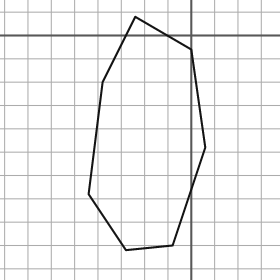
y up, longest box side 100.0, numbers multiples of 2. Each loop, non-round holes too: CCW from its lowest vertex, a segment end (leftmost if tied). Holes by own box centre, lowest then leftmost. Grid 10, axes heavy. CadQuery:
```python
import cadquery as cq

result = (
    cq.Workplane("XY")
    .moveTo(-28.0, -92.0)
    .lineTo(-8.0, -90.0)
    .lineTo(6.0, -48.0)
    .lineTo(0.0, -6.0)
    .lineTo(-24.0, 8.0)
    .lineTo(-38.0, -20.0)
    .lineTo(-44.0, -68.0)
    .close()
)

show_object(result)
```